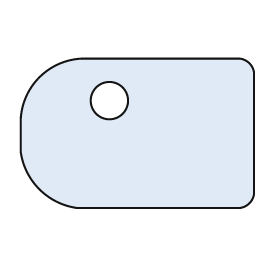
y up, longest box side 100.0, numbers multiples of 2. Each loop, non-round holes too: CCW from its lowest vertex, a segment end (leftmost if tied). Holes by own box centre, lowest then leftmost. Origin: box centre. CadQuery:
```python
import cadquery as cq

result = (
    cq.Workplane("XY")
    .moveTo(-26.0, -32.0)
    .lineTo(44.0, -32.0)
    .threePointArc((48.0, -30.0), (50.0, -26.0))
    .lineTo(50.0, 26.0)
    .threePointArc((48.0, 30.0), (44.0, 32.0))
    .lineTo(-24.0, 32.0)
    .threePointArc((-42.0, 24.0), (-50.0, 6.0))
    .lineTo(-50.0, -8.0)
    .threePointArc((-42.0, -24.0), (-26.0, -32.0))
    .close()
    .moveTo(-12.0, 14.0)
    .circle(8.0)
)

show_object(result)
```